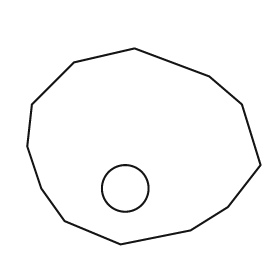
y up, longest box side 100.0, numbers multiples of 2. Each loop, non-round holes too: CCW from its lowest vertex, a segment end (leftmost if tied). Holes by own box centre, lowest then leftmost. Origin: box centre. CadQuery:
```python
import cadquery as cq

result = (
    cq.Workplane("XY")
    .moveTo(-10.0, -42.0)
    .lineTo(20.0, -36.0)
    .lineTo(36.0, -26.0)
    .lineTo(50.0, -8.0)
    .lineTo(42.0, 18.0)
    .lineTo(28.0, 30.0)
    .lineTo(-4.0, 42.0)
    .lineTo(-30.0, 36.0)
    .lineTo(-48.0, 18.0)
    .lineTo(-50.0, 0.0)
    .lineTo(-44.0, -18.0)
    .lineTo(-34.0, -32.0)
    .close()
    .moveTo(-8.0, -18.0)
    .circle(10.0)
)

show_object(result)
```